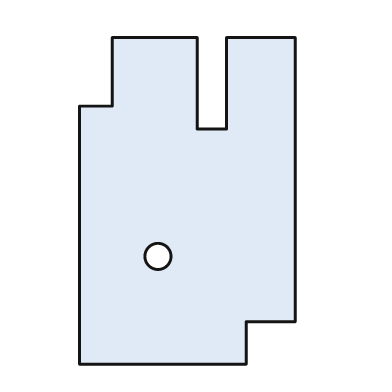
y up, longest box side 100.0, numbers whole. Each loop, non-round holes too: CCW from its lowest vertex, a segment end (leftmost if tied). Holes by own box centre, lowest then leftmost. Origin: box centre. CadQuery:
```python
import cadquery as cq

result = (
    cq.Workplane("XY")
    .moveTo(-33.0, -50.0)
    .lineTo(18.0, -50.0)
    .lineTo(18.0, -37.0)
    .lineTo(33.0, -37.0)
    .lineTo(33.0, 50.0)
    .lineTo(12.0, 50.0)
    .lineTo(12.0, 22.0)
    .lineTo(3.0, 22.0)
    .lineTo(3.0, 50.0)
    .lineTo(-23.0, 50.0)
    .lineTo(-23.0, 29.0)
    .lineTo(-33.0, 29.0)
    .close()
    .moveTo(-9.0, -17.0)
    .circle(4.0)
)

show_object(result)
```